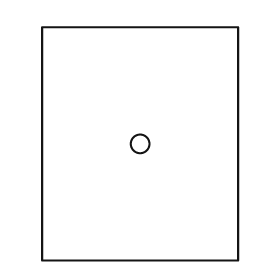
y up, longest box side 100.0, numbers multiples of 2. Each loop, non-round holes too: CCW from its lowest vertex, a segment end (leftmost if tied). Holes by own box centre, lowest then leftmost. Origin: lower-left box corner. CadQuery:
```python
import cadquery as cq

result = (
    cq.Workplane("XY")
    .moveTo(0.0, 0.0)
    .lineTo(84.0, 0.0)
    .lineTo(84.0, 100.0)
    .lineTo(0.0, 100.0)
    .close()
    .moveTo(42.0, 50.0)
    .circle(4.0)
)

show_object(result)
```